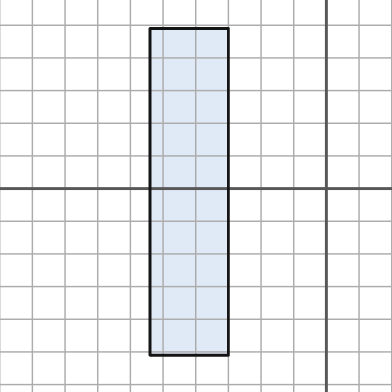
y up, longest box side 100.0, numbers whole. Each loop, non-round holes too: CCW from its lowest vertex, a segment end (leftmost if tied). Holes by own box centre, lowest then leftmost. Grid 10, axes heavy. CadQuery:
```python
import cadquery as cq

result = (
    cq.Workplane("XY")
    .moveTo(-54.0, -51.0)
    .lineTo(-30.0, -51.0)
    .lineTo(-30.0, 49.0)
    .lineTo(-54.0, 49.0)
    .close()
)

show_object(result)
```